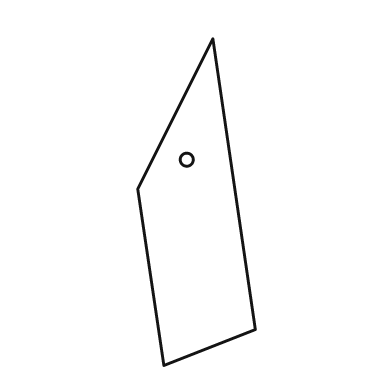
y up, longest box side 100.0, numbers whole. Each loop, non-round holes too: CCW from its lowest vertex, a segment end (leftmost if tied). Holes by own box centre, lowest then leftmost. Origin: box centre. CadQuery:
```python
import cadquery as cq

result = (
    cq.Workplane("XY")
    .moveTo(-10.0, -50.0)
    .lineTo(18.0, -39.0)
    .lineTo(5.0, 50.0)
    .lineTo(-18.0, 4.0)
    .close()
    .moveTo(-3.0, 13.0)
    .circle(2.0)
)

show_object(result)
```